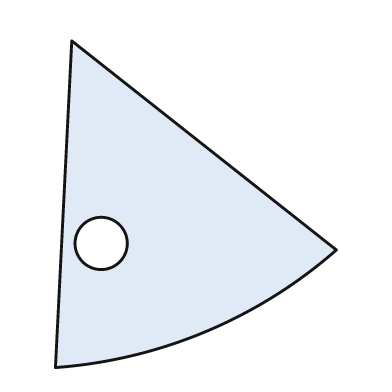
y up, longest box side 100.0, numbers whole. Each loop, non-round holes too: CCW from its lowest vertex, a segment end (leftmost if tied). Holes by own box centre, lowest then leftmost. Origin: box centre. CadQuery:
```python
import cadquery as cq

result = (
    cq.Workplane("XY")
    .moveTo(-43.0, -50.0)
    .threePointArc((3.0, -39.0), (43.0, -14.0))
    .lineTo(-38.0, 50.0)
    .close()
    .moveTo(-29.0, -12.0)
    .circle(8.0)
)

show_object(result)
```